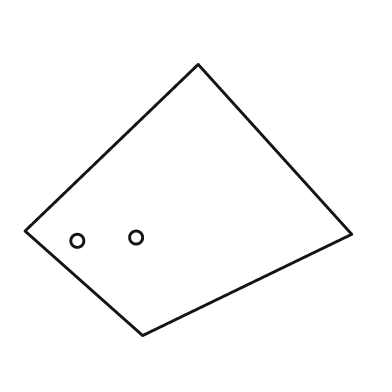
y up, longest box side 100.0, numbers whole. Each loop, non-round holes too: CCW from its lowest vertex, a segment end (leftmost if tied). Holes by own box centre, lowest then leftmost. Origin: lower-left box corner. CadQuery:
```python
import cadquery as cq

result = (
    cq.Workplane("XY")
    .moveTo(36.0, 0.0)
    .lineTo(100.0, 31.0)
    .lineTo(53.0, 83.0)
    .lineTo(0.0, 32.0)
    .close()
    .moveTo(16.0, 29.0)
    .circle(2.0)
    .moveTo(34.0, 30.0)
    .circle(2.0)
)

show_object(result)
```